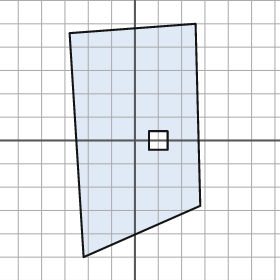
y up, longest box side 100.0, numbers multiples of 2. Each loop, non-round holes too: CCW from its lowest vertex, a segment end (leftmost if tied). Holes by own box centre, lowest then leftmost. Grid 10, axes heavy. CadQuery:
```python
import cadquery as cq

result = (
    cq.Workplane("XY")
    .moveTo(-22.0, -50.0)
    .lineTo(28.0, -28.0)
    .lineTo(26.0, 50.0)
    .lineTo(-28.0, 46.0)
    .close()
    .moveTo(6.0, -4.0)
    .lineTo(14.0, -4.0)
    .lineTo(14.0, 4.0)
    .lineTo(6.0, 4.0)
    .close()
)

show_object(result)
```